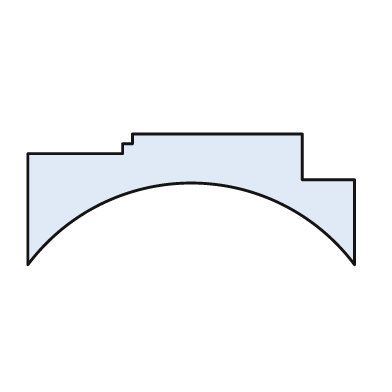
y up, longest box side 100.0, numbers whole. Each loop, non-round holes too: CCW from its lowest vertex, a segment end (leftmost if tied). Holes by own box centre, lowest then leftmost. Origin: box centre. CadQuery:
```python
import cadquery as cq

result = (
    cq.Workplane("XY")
    .moveTo(-50.0, -20.0)
    .threePointArc((0.0, 5.0), (50.0, -20.0))
    .lineTo(50.0, 6.0)
    .lineTo(34.0, 6.0)
    .lineTo(34.0, 20.0)
    .lineTo(-18.0, 20.0)
    .lineTo(-18.0, 17.0)
    .lineTo(-21.0, 17.0)
    .lineTo(-21.0, 14.0)
    .lineTo(-50.0, 14.0)
    .close()
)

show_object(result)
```